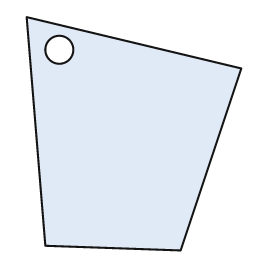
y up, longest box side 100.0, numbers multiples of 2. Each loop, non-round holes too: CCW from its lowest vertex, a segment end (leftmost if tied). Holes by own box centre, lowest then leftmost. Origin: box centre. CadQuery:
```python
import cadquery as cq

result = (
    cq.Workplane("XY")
    .moveTo(20.0, -50.0)
    .lineTo(46.0, 28.0)
    .lineTo(-46.0, 50.0)
    .lineTo(-38.0, -48.0)
    .close()
    .moveTo(-32.0, 36.0)
    .circle(6.0)
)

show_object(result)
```